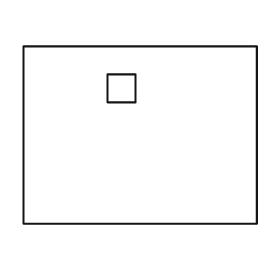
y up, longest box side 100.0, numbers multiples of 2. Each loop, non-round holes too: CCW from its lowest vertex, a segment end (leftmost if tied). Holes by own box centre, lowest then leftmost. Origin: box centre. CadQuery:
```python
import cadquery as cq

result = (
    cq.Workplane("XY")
    .moveTo(-50.0, -38.0)
    .lineTo(50.0, -38.0)
    .lineTo(50.0, 38.0)
    .lineTo(-50.0, 38.0)
    .close()
    .moveTo(-14.0, 14.0)
    .lineTo(-2.0, 14.0)
    .lineTo(-2.0, 26.0)
    .lineTo(-14.0, 26.0)
    .close()
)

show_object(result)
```